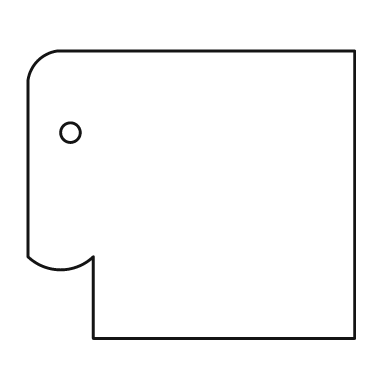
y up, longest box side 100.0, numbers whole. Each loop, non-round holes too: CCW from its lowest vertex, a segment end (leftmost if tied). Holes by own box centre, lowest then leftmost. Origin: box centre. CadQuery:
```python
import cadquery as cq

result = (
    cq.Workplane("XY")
    .moveTo(-30.0, -44.0)
    .lineTo(50.0, -44.0)
    .lineTo(50.0, 44.0)
    .lineTo(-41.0, 44.0)
    .threePointArc((-47.0, 41.0), (-50.0, 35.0))
    .lineTo(-50.0, -19.0)
    .threePointArc((-40.0, -23.0), (-30.0, -19.0))
    .close()
    .moveTo(-37.0, 19.0)
    .circle(3.0)
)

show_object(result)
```